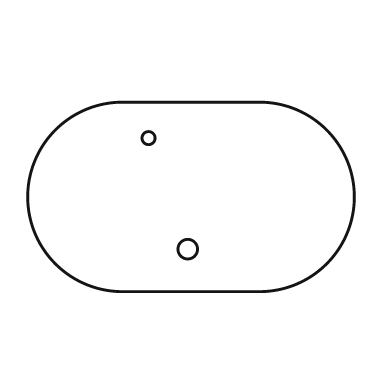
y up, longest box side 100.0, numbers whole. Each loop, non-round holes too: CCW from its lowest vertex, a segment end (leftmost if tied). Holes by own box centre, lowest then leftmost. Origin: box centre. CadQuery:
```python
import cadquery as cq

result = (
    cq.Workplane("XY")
    .moveTo(-21.0, -29.0)
    .lineTo(21.0, -29.0)
    .threePointArc((50.0, 0.0), (21.0, 29.0))
    .lineTo(-21.0, 29.0)
    .threePointArc((-50.0, 0.0), (-21.0, -29.0))
    .close()
    .moveTo(-1.0, -16.0)
    .circle(3.0)
    .moveTo(-13.0, 18.0)
    .circle(2.0)
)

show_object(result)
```